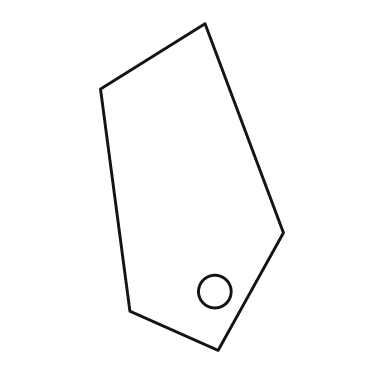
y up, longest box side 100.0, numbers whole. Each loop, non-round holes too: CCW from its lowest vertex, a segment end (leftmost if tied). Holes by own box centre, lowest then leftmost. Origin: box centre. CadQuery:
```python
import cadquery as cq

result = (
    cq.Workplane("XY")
    .moveTo(8.0, -50.0)
    .lineTo(28.0, -14.0)
    .lineTo(4.0, 50.0)
    .lineTo(-28.0, 30.0)
    .lineTo(-19.0, -38.0)
    .close()
    .moveTo(7.0, -32.0)
    .circle(5.0)
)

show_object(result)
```